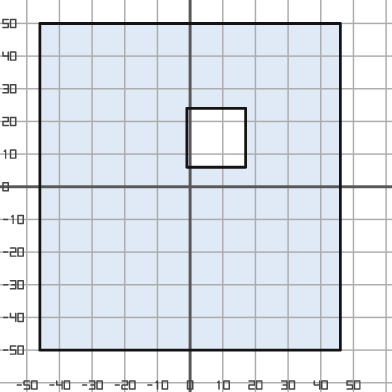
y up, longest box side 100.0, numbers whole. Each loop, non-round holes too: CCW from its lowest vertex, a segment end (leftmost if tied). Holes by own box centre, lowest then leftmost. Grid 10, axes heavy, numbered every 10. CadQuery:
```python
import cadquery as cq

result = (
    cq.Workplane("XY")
    .moveTo(-46.0, -50.0)
    .lineTo(46.0, -50.0)
    .lineTo(46.0, 50.0)
    .lineTo(-46.0, 50.0)
    .close()
    .moveTo(-1.0, 6.0)
    .lineTo(17.0, 6.0)
    .lineTo(17.0, 24.0)
    .lineTo(-1.0, 24.0)
    .close()
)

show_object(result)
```